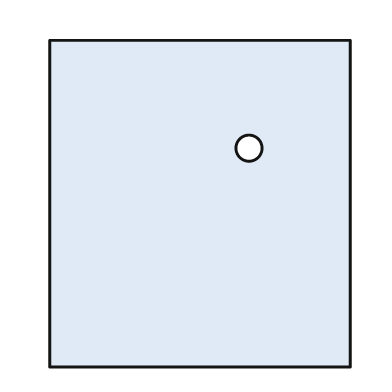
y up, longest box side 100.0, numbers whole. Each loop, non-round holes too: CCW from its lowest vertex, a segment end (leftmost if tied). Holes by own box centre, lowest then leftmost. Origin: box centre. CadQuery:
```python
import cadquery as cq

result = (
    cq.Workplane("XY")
    .moveTo(-46.0, -50.0)
    .lineTo(46.0, -50.0)
    .lineTo(46.0, 50.0)
    .lineTo(-46.0, 50.0)
    .close()
    .moveTo(15.0, 17.0)
    .circle(4.0)
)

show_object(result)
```